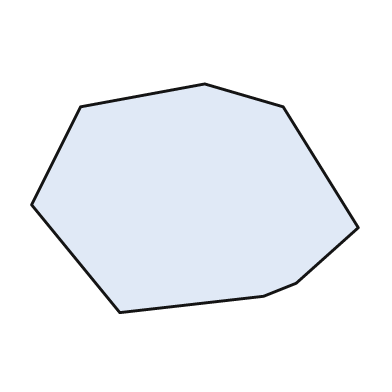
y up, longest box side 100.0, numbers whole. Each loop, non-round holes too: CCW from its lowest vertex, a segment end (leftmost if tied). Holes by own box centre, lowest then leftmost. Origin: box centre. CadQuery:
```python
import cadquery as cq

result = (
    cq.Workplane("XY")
    .moveTo(-23.0, -35.0)
    .lineTo(21.0, -30.0)
    .lineTo(31.0, -26.0)
    .lineTo(50.0, -9.0)
    .lineTo(27.0, 28.0)
    .lineTo(3.0, 35.0)
    .lineTo(-35.0, 28.0)
    .lineTo(-50.0, -2.0)
    .close()
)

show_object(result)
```